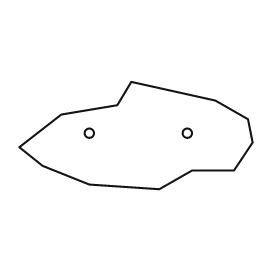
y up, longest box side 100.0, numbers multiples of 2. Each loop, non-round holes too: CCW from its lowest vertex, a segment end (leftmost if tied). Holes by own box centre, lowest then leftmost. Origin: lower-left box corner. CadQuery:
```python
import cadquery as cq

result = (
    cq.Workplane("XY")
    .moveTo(60.0, 0.0)
    .lineTo(74.0, 8.0)
    .lineTo(92.0, 8.0)
    .lineTo(100.0, 20.0)
    .lineTo(98.0, 30.0)
    .lineTo(84.0, 38.0)
    .lineTo(48.0, 46.0)
    .lineTo(42.0, 36.0)
    .lineTo(18.0, 32.0)
    .lineTo(0.0, 18.0)
    .lineTo(10.0, 10.0)
    .lineTo(30.0, 2.0)
    .close()
    .moveTo(30.0, 24.0)
    .circle(2.0)
    .moveTo(72.0, 24.0)
    .circle(2.0)
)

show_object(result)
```